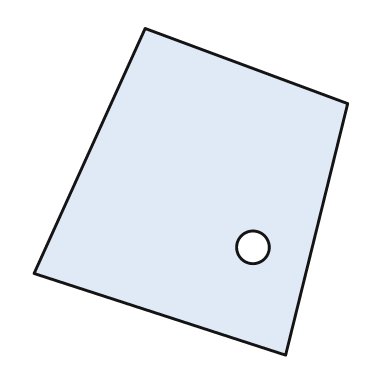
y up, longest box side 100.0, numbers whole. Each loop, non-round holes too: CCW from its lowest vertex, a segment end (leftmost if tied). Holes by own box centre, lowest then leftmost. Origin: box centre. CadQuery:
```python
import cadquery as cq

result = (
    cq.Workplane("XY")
    .moveTo(29.0, -50.0)
    .lineTo(48.0, 27.0)
    .lineTo(-14.0, 50.0)
    .lineTo(-48.0, -25.0)
    .close()
    .moveTo(19.0, -17.0)
    .circle(5.0)
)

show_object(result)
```